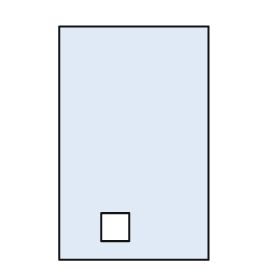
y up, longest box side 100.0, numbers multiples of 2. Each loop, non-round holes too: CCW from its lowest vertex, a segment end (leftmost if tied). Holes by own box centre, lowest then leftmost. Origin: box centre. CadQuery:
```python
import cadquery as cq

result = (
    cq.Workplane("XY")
    .moveTo(-32.0, -50.0)
    .lineTo(32.0, -50.0)
    .lineTo(32.0, 50.0)
    .lineTo(-32.0, 50.0)
    .close()
    .moveTo(-14.0, -42.0)
    .lineTo(-2.0, -42.0)
    .lineTo(-2.0, -30.0)
    .lineTo(-14.0, -30.0)
    .close()
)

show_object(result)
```